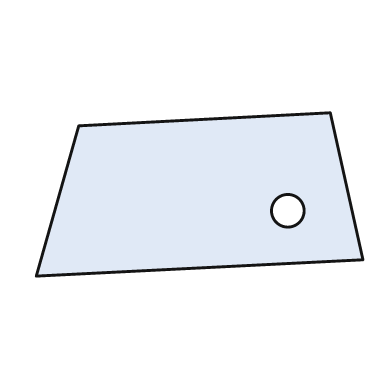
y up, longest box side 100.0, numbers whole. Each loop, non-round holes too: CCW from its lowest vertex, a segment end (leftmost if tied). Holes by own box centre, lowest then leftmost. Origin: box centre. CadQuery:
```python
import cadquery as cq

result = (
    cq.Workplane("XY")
    .moveTo(-50.0, -25.0)
    .lineTo(50.0, -20.0)
    .lineTo(40.0, 25.0)
    .lineTo(-37.0, 21.0)
    .close()
    .moveTo(27.0, -5.0)
    .circle(5.0)
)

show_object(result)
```